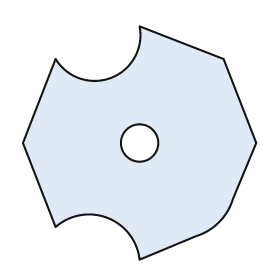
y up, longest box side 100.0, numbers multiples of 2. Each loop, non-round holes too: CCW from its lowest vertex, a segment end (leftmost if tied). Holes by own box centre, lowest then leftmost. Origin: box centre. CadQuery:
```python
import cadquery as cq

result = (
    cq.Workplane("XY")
    .moveTo(0.0, -50.0)
    .lineTo(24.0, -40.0)
    .threePointArc((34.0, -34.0), (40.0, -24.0))
    .lineTo(50.0, 0.0)
    .lineTo(36.0, 36.0)
    .lineTo(0.0, 50.0)
    .threePointArc((-12.0, 28.0), (-36.0, 36.0))
    .lineTo(-50.0, 0.0)
    .lineTo(-36.0, -36.0)
    .threePointArc((-14.0, -32.0), (0.0, -50.0))
    .close()
    .moveTo(0.0, 0.0)
    .circle(8.0)
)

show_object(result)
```